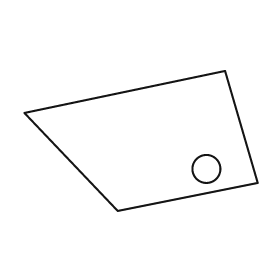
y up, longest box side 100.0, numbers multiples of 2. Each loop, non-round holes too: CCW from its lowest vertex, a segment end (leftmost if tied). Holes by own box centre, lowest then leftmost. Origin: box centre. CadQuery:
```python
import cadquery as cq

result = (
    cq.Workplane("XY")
    .moveTo(-10.0, -30.0)
    .lineTo(50.0, -18.0)
    .lineTo(36.0, 30.0)
    .lineTo(-50.0, 12.0)
    .close()
    .moveTo(28.0, -12.0)
    .circle(6.0)
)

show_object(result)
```